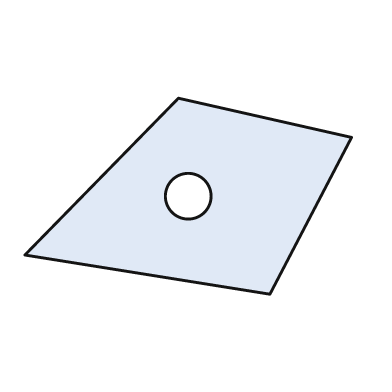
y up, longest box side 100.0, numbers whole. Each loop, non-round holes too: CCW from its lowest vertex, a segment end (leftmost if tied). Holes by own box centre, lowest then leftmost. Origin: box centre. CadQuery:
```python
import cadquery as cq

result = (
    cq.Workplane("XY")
    .moveTo(25.0, -30.0)
    .lineTo(50.0, 18.0)
    .lineTo(-3.0, 30.0)
    .lineTo(-50.0, -18.0)
    .close()
    .moveTo(0.0, 0.0)
    .circle(7.0)
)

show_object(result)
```